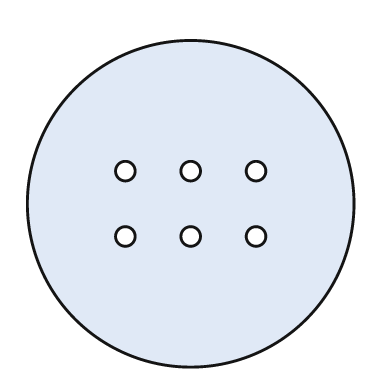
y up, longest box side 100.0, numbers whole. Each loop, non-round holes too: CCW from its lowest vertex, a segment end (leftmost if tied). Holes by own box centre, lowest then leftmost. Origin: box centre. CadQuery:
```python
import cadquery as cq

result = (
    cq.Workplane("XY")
    .moveTo(0.0, 0.0)
    .circle(50.0)
    .moveTo(-20.0, -10.0)
    .circle(3.0)
    .moveTo(0.0, -10.0)
    .circle(3.0)
    .moveTo(20.0, -10.0)
    .circle(3.0)
    .moveTo(-20.0, 10.0)
    .circle(3.0)
    .moveTo(0.0, 10.0)
    .circle(3.0)
    .moveTo(20.0, 10.0)
    .circle(3.0)
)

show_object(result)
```